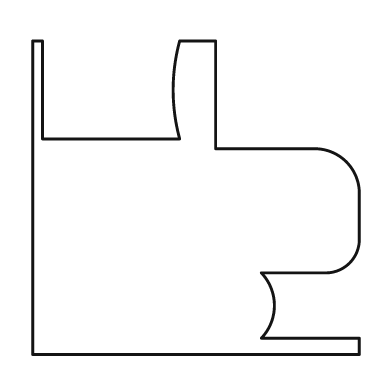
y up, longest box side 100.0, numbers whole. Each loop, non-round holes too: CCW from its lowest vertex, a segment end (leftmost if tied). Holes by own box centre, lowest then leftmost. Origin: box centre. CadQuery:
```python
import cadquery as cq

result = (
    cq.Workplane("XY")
    .moveTo(-50.0, -48.0)
    .lineTo(50.0, -48.0)
    .lineTo(50.0, -43.0)
    .lineTo(20.0, -43.0)
    .threePointArc((24.0, -33.0), (20.0, -23.0))
    .lineTo(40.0, -23.0)
    .threePointArc((47.0, -20.0), (50.0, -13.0))
    .lineTo(50.0, 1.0)
    .threePointArc((46.0, 11.0), (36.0, 15.0))
    .lineTo(6.0, 15.0)
    .lineTo(6.0, 48.0)
    .lineTo(-5.0, 48.0)
    .threePointArc((-7.0, 33.0), (-5.0, 18.0))
    .lineTo(-47.0, 18.0)
    .lineTo(-47.0, 48.0)
    .lineTo(-50.0, 48.0)
    .close()
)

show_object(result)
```